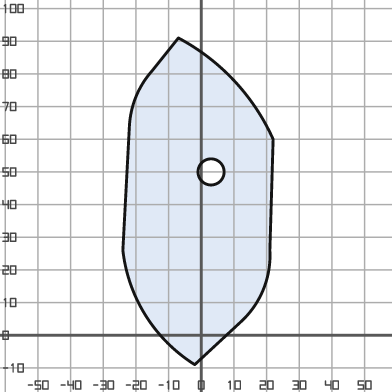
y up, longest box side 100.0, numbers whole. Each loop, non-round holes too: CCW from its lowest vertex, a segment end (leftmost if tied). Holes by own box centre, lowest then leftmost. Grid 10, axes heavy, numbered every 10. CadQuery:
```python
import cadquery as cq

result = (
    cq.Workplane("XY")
    .moveTo(-2.0, -9.0)
    .lineTo(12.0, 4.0)
    .threePointArc((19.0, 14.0), (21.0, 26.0))
    .lineTo(22.0, 60.0)
    .threePointArc((10.0, 78.0), (-7.0, 91.0))
    .lineTo(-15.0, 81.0)
    .threePointArc((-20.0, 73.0), (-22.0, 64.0))
    .lineTo(-24.0, 26.0)
    .threePointArc((-17.0, 6.0), (-2.0, -9.0))
    .close()
    .moveTo(3.0, 50.0)
    .circle(4.0)
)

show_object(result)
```